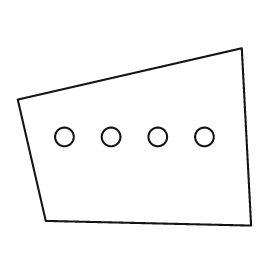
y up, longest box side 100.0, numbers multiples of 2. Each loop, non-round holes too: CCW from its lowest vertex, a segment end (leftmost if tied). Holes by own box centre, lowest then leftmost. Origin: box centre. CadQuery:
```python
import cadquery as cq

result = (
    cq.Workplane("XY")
    .moveTo(50.0, -38.0)
    .lineTo(46.0, 38.0)
    .lineTo(-50.0, 16.0)
    .lineTo(-38.0, -36.0)
    .close()
    .moveTo(-30.0, 0.0)
    .circle(4.0)
    .moveTo(-10.0, 0.0)
    .circle(4.0)
    .moveTo(10.0, 0.0)
    .circle(4.0)
    .moveTo(30.0, 0.0)
    .circle(4.0)
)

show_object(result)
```